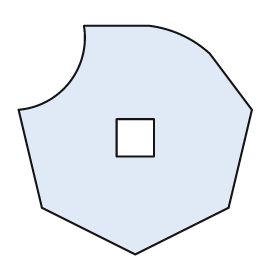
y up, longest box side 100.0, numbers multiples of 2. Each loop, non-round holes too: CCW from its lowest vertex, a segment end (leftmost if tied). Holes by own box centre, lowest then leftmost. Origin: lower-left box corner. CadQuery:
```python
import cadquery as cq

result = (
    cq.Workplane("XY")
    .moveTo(50.0, 0.0)
    .lineTo(90.0, 20.0)
    .lineTo(100.0, 62.0)
    .lineTo(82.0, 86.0)
    .threePointArc((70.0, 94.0), (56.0, 98.0))
    .lineTo(28.0, 98.0)
    .threePointArc((22.0, 74.0), (0.0, 62.0))
    .lineTo(10.0, 20.0)
    .close()
    .moveTo(42.0, 42.0)
    .lineTo(58.0, 42.0)
    .lineTo(58.0, 58.0)
    .lineTo(42.0, 58.0)
    .close()
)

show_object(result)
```